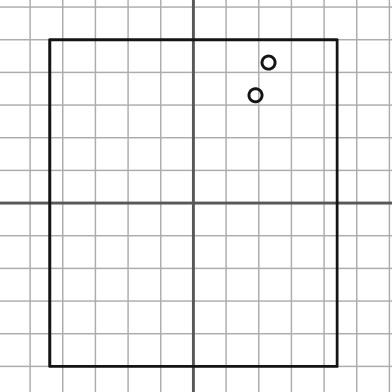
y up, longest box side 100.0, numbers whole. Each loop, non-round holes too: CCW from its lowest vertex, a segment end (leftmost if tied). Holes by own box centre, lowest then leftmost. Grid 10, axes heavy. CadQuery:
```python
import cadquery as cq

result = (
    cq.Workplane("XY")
    .moveTo(-44.0, -50.0)
    .lineTo(44.0, -50.0)
    .lineTo(44.0, 50.0)
    .lineTo(-44.0, 50.0)
    .close()
    .moveTo(19.0, 33.0)
    .circle(2.0)
    .moveTo(23.0, 43.0)
    .circle(2.0)
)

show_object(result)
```